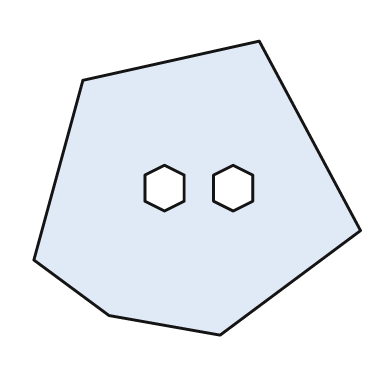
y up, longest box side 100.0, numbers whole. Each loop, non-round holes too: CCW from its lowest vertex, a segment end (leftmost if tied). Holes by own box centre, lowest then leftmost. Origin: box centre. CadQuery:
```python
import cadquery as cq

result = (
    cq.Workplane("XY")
    .moveTo(7.0, -45.0)
    .lineTo(50.0, -13.0)
    .lineTo(19.0, 45.0)
    .lineTo(-35.0, 33.0)
    .lineTo(-50.0, -22.0)
    .lineTo(-27.0, -39.0)
    .close()
    .moveTo(-10.0, -7.0)
    .lineTo(-4.0, -4.0)
    .lineTo(-4.0, 4.0)
    .lineTo(-10.0, 7.0)
    .lineTo(-16.0, 4.0)
    .lineTo(-16.0, -4.0)
    .close()
    .moveTo(11.0, -7.0)
    .lineTo(17.0, -4.0)
    .lineTo(17.0, 4.0)
    .lineTo(11.0, 7.0)
    .lineTo(5.0, 4.0)
    .lineTo(5.0, -4.0)
    .close()
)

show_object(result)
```